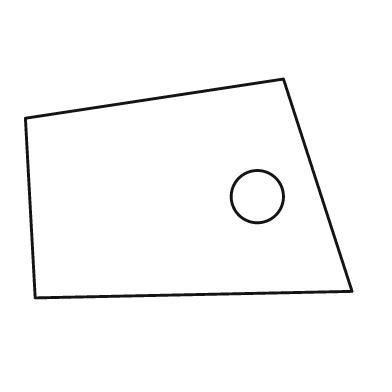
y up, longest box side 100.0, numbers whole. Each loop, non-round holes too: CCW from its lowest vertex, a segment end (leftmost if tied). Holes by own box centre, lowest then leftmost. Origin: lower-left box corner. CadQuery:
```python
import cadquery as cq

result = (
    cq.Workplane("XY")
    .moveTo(3.0, 0.0)
    .lineTo(100.0, 2.0)
    .lineTo(79.0, 67.0)
    .lineTo(0.0, 55.0)
    .close()
    .moveTo(71.0, 31.0)
    .circle(8.0)
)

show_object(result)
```